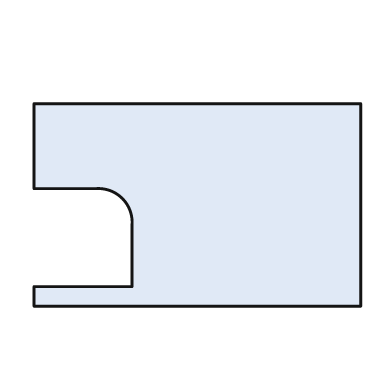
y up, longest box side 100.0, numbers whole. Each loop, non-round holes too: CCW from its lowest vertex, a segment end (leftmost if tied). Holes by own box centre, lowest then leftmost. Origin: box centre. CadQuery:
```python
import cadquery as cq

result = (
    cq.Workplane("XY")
    .moveTo(-50.0, -31.0)
    .lineTo(50.0, -31.0)
    .lineTo(50.0, 31.0)
    .lineTo(-50.0, 31.0)
    .lineTo(-50.0, 5.0)
    .lineTo(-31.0, 5.0)
    .threePointArc((-23.0, 2.0), (-20.0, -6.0))
    .lineTo(-20.0, -25.0)
    .lineTo(-50.0, -25.0)
    .close()
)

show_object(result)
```